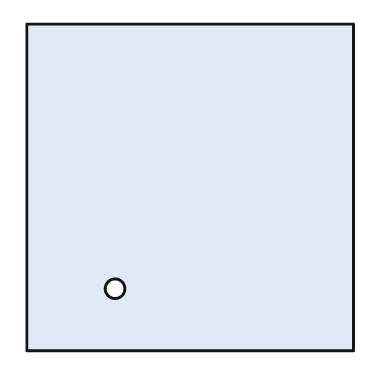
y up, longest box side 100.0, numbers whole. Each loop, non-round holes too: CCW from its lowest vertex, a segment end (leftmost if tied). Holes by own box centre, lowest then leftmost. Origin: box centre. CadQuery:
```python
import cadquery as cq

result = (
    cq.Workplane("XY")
    .moveTo(-50.0, -50.0)
    .lineTo(50.0, -50.0)
    .lineTo(50.0, 50.0)
    .lineTo(-50.0, 50.0)
    .close()
    .moveTo(-23.0, -31.0)
    .circle(3.0)
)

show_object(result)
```